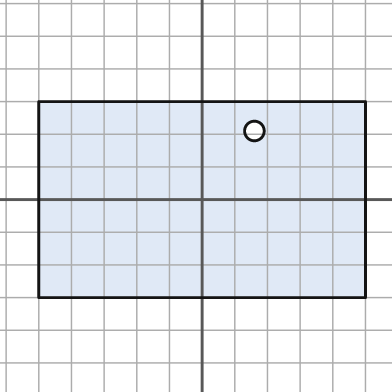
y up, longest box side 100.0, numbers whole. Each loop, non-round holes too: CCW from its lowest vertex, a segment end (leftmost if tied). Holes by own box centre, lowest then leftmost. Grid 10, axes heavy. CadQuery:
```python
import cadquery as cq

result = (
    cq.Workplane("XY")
    .moveTo(-50.0, -30.0)
    .lineTo(50.0, -30.0)
    .lineTo(50.0, 30.0)
    .lineTo(-50.0, 30.0)
    .close()
    .moveTo(16.0, 21.0)
    .circle(3.0)
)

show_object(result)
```